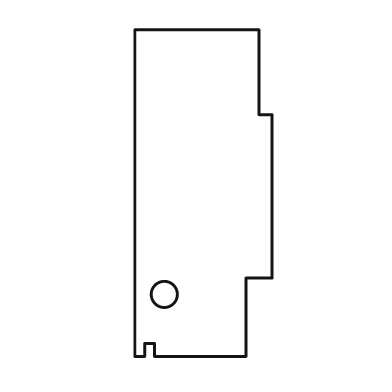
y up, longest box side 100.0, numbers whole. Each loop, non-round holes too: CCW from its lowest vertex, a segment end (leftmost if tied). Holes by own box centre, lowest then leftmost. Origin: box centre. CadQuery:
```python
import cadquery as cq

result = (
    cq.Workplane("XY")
    .moveTo(-21.0, -50.0)
    .lineTo(-18.0, -50.0)
    .lineTo(-18.0, -46.0)
    .lineTo(-15.0, -46.0)
    .lineTo(-15.0, -50.0)
    .lineTo(13.0, -50.0)
    .lineTo(13.0, -26.0)
    .lineTo(21.0, -26.0)
    .lineTo(21.0, 24.0)
    .lineTo(17.0, 24.0)
    .lineTo(17.0, 50.0)
    .lineTo(-21.0, 50.0)
    .close()
    .moveTo(-12.0, -31.0)
    .circle(4.0)
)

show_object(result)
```